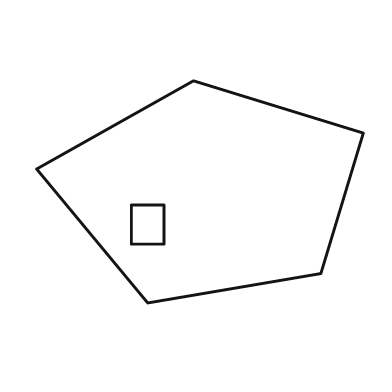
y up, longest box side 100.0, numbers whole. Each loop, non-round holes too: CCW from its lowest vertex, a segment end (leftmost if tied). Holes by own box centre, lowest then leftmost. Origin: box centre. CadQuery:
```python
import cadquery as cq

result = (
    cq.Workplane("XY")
    .moveTo(-16.0, -34.0)
    .lineTo(37.0, -25.0)
    .lineTo(50.0, 18.0)
    .lineTo(-2.0, 34.0)
    .lineTo(-50.0, 7.0)
    .close()
    .moveTo(-21.0, -16.0)
    .lineTo(-11.0, -16.0)
    .lineTo(-11.0, -4.0)
    .lineTo(-21.0, -4.0)
    .close()
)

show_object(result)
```